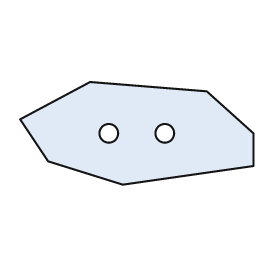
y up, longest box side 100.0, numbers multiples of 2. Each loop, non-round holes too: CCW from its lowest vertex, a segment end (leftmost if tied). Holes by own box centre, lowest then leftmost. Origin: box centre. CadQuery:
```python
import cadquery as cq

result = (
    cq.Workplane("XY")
    .moveTo(-6.0, -22.0)
    .lineTo(50.0, -14.0)
    .lineTo(50.0, 0.0)
    .lineTo(30.0, 18.0)
    .lineTo(-20.0, 22.0)
    .lineTo(-50.0, 6.0)
    .lineTo(-38.0, -12.0)
    .close()
    .moveTo(-12.0, 0.0)
    .circle(4.0)
    .moveTo(12.0, 0.0)
    .circle(4.0)
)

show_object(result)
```